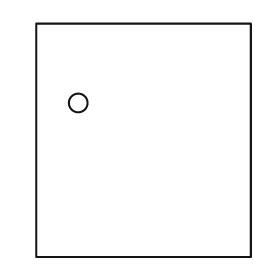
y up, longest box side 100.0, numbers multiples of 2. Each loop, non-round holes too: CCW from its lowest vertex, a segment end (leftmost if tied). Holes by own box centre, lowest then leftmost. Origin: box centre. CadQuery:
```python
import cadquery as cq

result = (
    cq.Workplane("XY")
    .moveTo(-46.0, -50.0)
    .lineTo(46.0, -50.0)
    .lineTo(46.0, 50.0)
    .lineTo(-46.0, 50.0)
    .close()
    .moveTo(-28.0, 16.0)
    .circle(4.0)
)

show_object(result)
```